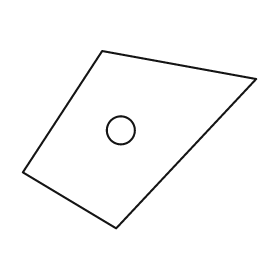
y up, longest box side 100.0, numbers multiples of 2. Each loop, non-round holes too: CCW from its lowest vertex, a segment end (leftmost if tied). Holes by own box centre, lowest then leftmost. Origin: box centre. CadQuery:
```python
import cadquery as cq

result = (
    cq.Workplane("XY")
    .moveTo(-10.0, -38.0)
    .lineTo(50.0, 26.0)
    .lineTo(-16.0, 38.0)
    .lineTo(-50.0, -14.0)
    .close()
    .moveTo(-8.0, 4.0)
    .circle(6.0)
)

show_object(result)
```